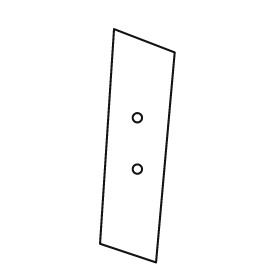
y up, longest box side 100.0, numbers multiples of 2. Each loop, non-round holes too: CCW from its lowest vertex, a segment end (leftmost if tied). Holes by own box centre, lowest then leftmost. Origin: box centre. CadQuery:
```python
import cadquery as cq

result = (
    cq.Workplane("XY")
    .moveTo(8.0, -50.0)
    .lineTo(16.0, 40.0)
    .lineTo(-10.0, 50.0)
    .lineTo(-16.0, -42.0)
    .close()
    .moveTo(0.0, -10.0)
    .circle(2.0)
    .moveTo(0.0, 12.0)
    .circle(2.0)
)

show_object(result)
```